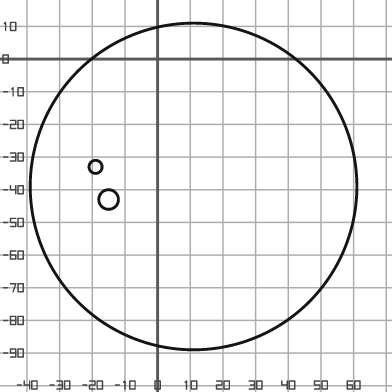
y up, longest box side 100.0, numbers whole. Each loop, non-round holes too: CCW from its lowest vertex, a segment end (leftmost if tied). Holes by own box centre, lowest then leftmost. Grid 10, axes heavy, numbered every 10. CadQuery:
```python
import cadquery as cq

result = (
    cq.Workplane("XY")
    .moveTo(11.0, -39.0)
    .circle(50.0)
    .moveTo(-15.0, -43.0)
    .circle(3.0)
    .moveTo(-19.0, -33.0)
    .circle(2.0)
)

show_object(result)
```